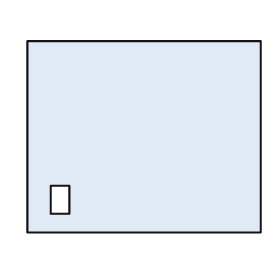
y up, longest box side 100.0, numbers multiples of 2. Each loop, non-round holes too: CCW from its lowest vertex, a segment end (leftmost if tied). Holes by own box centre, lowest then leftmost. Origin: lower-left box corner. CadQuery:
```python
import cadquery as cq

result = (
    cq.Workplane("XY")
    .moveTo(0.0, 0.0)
    .lineTo(100.0, 0.0)
    .lineTo(100.0, 82.0)
    .lineTo(0.0, 82.0)
    .close()
    .moveTo(10.0, 8.0)
    .lineTo(18.0, 8.0)
    .lineTo(18.0, 20.0)
    .lineTo(10.0, 20.0)
    .close()
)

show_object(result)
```